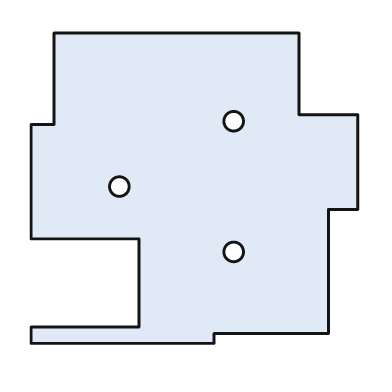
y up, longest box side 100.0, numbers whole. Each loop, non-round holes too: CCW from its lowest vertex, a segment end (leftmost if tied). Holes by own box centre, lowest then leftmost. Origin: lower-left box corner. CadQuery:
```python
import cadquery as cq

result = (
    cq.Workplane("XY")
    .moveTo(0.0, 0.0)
    .lineTo(56.0, 0.0)
    .lineTo(56.0, 3.0)
    .lineTo(91.0, 3.0)
    .lineTo(91.0, 41.0)
    .lineTo(100.0, 41.0)
    .lineTo(100.0, 70.0)
    .lineTo(82.0, 70.0)
    .lineTo(82.0, 95.0)
    .lineTo(7.0, 95.0)
    .lineTo(7.0, 67.0)
    .lineTo(0.0, 67.0)
    .lineTo(0.0, 32.0)
    .lineTo(33.0, 32.0)
    .lineTo(33.0, 5.0)
    .lineTo(0.0, 5.0)
    .close()
    .moveTo(62.0, 28.0)
    .circle(3.0)
    .moveTo(27.0, 48.0)
    .circle(3.0)
    .moveTo(62.0, 68.0)
    .circle(3.0)
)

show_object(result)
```